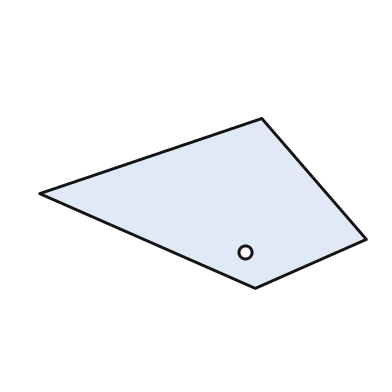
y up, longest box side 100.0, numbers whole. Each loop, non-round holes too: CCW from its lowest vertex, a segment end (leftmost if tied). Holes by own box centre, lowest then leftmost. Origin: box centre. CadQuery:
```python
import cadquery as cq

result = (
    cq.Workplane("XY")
    .moveTo(16.0, -26.0)
    .lineTo(50.0, -11.0)
    .lineTo(18.0, 26.0)
    .lineTo(-50.0, 3.0)
    .close()
    .moveTo(13.0, -15.0)
    .circle(2.0)
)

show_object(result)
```